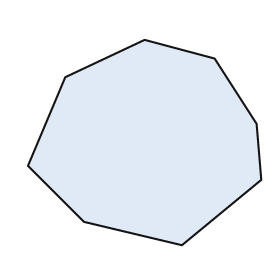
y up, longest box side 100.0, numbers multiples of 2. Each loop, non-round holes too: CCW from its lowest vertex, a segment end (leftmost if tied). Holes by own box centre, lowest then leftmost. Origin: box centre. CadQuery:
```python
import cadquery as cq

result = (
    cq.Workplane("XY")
    .moveTo(16.0, -44.0)
    .lineTo(50.0, -16.0)
    .lineTo(48.0, 8.0)
    .lineTo(30.0, 36.0)
    .lineTo(0.0, 44.0)
    .lineTo(-34.0, 28.0)
    .lineTo(-50.0, -10.0)
    .lineTo(-26.0, -34.0)
    .close()
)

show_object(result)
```